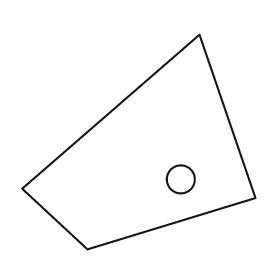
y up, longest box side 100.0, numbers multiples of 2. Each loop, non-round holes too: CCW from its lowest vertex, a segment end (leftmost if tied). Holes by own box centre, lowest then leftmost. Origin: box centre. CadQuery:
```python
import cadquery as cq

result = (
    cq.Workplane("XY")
    .moveTo(-22.0, -46.0)
    .lineTo(50.0, -24.0)
    .lineTo(26.0, 46.0)
    .lineTo(-50.0, -20.0)
    .close()
    .moveTo(18.0, -16.0)
    .circle(6.0)
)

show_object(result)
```